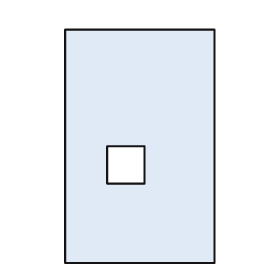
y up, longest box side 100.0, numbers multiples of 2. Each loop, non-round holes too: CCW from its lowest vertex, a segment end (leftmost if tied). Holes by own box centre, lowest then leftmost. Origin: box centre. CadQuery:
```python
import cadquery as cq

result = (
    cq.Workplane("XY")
    .moveTo(-32.0, -50.0)
    .lineTo(32.0, -50.0)
    .lineTo(32.0, 50.0)
    .lineTo(-32.0, 50.0)
    .close()
    .moveTo(-14.0, -16.0)
    .lineTo(2.0, -16.0)
    .lineTo(2.0, 0.0)
    .lineTo(-14.0, 0.0)
    .close()
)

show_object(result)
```